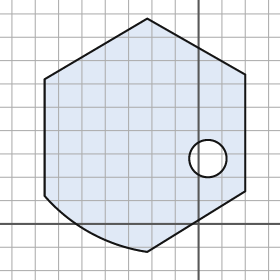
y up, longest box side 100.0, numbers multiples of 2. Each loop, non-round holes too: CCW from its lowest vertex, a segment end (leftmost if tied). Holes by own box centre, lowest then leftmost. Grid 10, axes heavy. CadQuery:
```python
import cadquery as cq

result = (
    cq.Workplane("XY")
    .moveTo(-22.0, -12.0)
    .lineTo(20.0, 14.0)
    .lineTo(20.0, 64.0)
    .lineTo(-22.0, 88.0)
    .lineTo(-66.0, 62.0)
    .lineTo(-66.0, 12.0)
    .threePointArc((-46.0, -4.0), (-22.0, -12.0))
    .close()
    .moveTo(4.0, 28.0)
    .circle(8.0)
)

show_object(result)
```